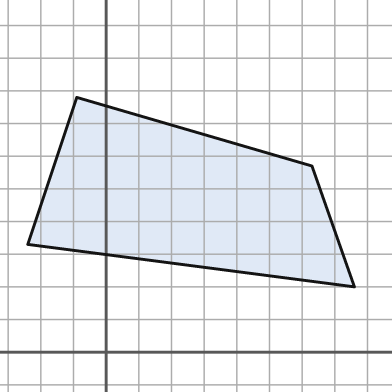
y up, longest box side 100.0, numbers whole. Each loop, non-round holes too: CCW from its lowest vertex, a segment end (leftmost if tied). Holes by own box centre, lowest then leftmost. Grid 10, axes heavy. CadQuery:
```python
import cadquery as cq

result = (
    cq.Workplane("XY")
    .moveTo(76.0, 20.0)
    .lineTo(63.0, 57.0)
    .lineTo(-9.0, 78.0)
    .lineTo(-24.0, 33.0)
    .close()
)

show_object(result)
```